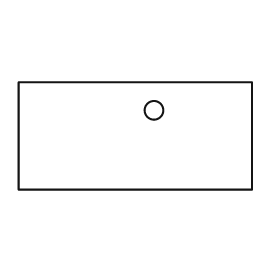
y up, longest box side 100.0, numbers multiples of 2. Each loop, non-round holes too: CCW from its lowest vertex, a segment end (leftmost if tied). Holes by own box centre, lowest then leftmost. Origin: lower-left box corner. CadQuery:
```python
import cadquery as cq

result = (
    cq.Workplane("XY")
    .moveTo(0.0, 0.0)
    .lineTo(100.0, 0.0)
    .lineTo(100.0, 46.0)
    .lineTo(0.0, 46.0)
    .close()
    .moveTo(58.0, 34.0)
    .circle(4.0)
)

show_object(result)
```